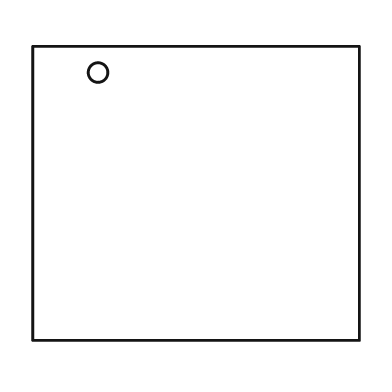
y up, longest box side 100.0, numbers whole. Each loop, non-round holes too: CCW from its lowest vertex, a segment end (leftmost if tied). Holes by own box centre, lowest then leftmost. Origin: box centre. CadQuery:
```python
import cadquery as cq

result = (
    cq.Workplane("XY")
    .moveTo(-50.0, -45.0)
    .lineTo(50.0, -45.0)
    .lineTo(50.0, 45.0)
    .lineTo(-50.0, 45.0)
    .close()
    .moveTo(-30.0, 37.0)
    .circle(3.0)
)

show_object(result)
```